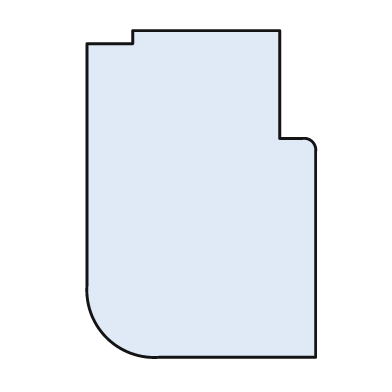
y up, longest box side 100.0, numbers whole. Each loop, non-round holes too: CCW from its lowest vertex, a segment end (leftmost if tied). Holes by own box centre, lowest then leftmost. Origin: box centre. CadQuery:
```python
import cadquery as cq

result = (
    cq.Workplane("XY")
    .moveTo(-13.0, -50.0)
    .lineTo(35.0, -50.0)
    .lineTo(35.0, 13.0)
    .threePointArc((34.0, 16.0), (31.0, 17.0))
    .lineTo(24.0, 17.0)
    .lineTo(24.0, 50.0)
    .lineTo(-21.0, 50.0)
    .lineTo(-21.0, 46.0)
    .lineTo(-35.0, 46.0)
    .lineTo(-35.0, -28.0)
    .threePointArc((-29.0, -44.0), (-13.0, -50.0))
    .close()
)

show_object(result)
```